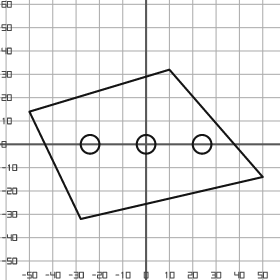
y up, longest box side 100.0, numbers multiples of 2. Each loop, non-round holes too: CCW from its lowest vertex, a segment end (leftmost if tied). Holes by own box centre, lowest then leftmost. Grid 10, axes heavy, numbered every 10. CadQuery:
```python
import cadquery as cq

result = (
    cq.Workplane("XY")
    .moveTo(-28.0, -32.0)
    .lineTo(50.0, -14.0)
    .lineTo(10.0, 32.0)
    .lineTo(-50.0, 14.0)
    .close()
    .moveTo(-24.0, 0.0)
    .circle(4.0)
    .moveTo(0.0, 0.0)
    .circle(4.0)
    .moveTo(24.0, 0.0)
    .circle(4.0)
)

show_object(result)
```